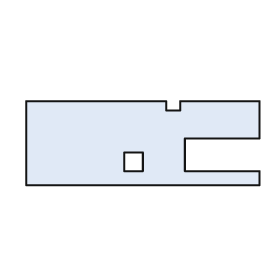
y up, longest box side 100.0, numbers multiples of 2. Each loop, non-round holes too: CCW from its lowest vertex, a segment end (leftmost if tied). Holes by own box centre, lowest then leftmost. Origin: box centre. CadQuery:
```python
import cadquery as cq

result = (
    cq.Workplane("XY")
    .moveTo(-50.0, -18.0)
    .lineTo(50.0, -18.0)
    .lineTo(50.0, -12.0)
    .lineTo(18.0, -12.0)
    .lineTo(18.0, 2.0)
    .lineTo(50.0, 2.0)
    .lineTo(50.0, 18.0)
    .lineTo(16.0, 18.0)
    .lineTo(16.0, 14.0)
    .lineTo(10.0, 14.0)
    .lineTo(10.0, 18.0)
    .lineTo(-50.0, 18.0)
    .close()
    .moveTo(-8.0, -12.0)
    .lineTo(0.0, -12.0)
    .lineTo(0.0, -4.0)
    .lineTo(-8.0, -4.0)
    .close()
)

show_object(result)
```